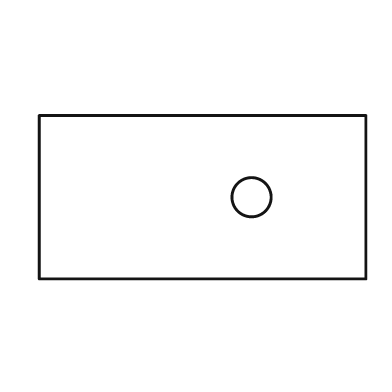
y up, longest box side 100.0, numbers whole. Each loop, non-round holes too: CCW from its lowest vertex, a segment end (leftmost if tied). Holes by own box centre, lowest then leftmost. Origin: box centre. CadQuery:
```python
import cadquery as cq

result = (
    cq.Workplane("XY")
    .moveTo(-50.0, -25.0)
    .lineTo(50.0, -25.0)
    .lineTo(50.0, 25.0)
    .lineTo(-50.0, 25.0)
    .close()
    .moveTo(15.0, 0.0)
    .circle(6.0)
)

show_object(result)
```